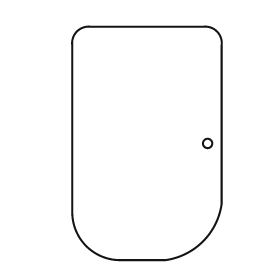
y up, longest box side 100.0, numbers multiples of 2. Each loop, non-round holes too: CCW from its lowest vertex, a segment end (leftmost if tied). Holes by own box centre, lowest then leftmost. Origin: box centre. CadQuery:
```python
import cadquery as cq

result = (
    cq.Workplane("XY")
    .moveTo(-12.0, -50.0)
    .lineTo(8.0, -50.0)
    .threePointArc((24.0, -42.0), (32.0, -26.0))
    .lineTo(32.0, 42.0)
    .threePointArc((30.0, 48.0), (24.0, 50.0))
    .lineTo(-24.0, 50.0)
    .threePointArc((-30.0, 48.0), (-32.0, 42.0))
    .lineTo(-32.0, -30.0)
    .threePointArc((-26.0, -44.0), (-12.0, -50.0))
    .close()
    .moveTo(26.0, 0.0)
    .circle(2.0)
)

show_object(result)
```